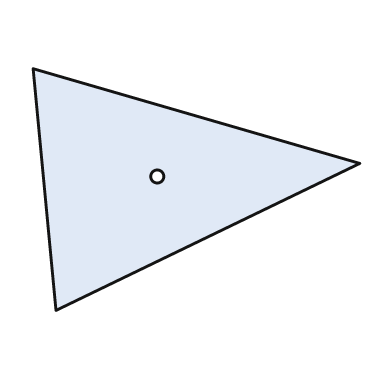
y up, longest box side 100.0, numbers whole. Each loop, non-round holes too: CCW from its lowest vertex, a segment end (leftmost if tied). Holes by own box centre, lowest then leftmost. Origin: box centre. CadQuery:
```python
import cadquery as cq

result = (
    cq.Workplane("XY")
    .moveTo(-43.0, -37.0)
    .lineTo(50.0, 8.0)
    .lineTo(-50.0, 37.0)
    .close()
    .moveTo(-12.0, 4.0)
    .circle(2.0)
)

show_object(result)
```